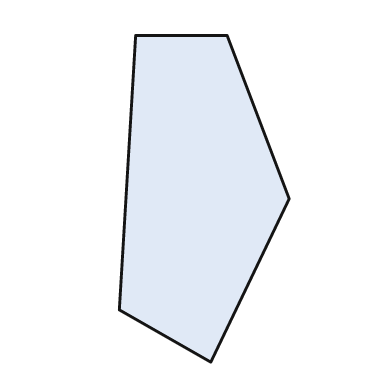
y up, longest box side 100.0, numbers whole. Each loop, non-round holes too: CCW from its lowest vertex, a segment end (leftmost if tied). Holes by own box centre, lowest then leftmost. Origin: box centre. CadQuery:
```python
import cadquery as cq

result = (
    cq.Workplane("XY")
    .moveTo(2.0, -50.0)
    .lineTo(26.0, 0.0)
    .lineTo(7.0, 50.0)
    .lineTo(-21.0, 50.0)
    .lineTo(-26.0, -34.0)
    .close()
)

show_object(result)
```